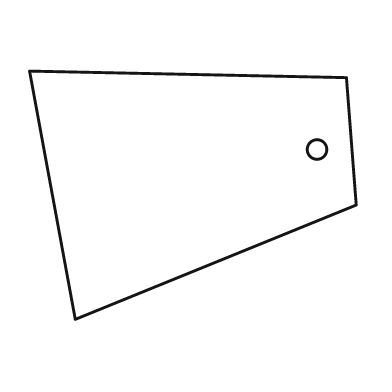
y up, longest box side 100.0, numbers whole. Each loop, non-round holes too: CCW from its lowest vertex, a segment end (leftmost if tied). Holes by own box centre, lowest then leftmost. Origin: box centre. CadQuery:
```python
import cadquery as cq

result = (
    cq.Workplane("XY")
    .moveTo(-36.0, -38.0)
    .lineTo(50.0, -3.0)
    .lineTo(47.0, 36.0)
    .lineTo(-50.0, 38.0)
    .close()
    .moveTo(38.0, 14.0)
    .circle(3.0)
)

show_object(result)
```